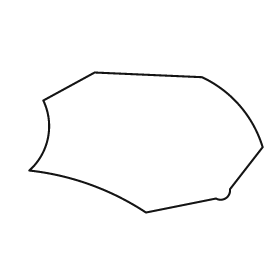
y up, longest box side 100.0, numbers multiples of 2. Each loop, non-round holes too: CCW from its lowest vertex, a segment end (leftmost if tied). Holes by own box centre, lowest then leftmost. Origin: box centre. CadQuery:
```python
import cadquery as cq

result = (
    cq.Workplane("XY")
    .moveTo(0.0, -30.0)
    .lineTo(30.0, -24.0)
    .threePointArc((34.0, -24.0), (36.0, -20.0))
    .lineTo(50.0, -2.0)
    .threePointArc((40.0, 16.0), (24.0, 28.0))
    .lineTo(-22.0, 30.0)
    .lineTo(-44.0, 18.0)
    .threePointArc((-42.0, 2.0), (-50.0, -12.0))
    .threePointArc((-24.0, -18.0), (0.0, -30.0))
    .close()
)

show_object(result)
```